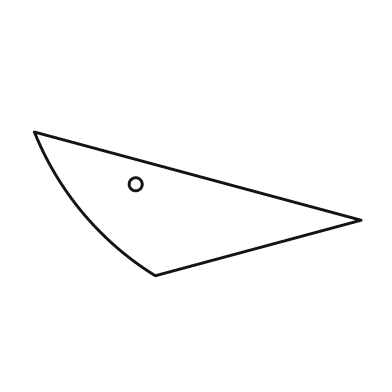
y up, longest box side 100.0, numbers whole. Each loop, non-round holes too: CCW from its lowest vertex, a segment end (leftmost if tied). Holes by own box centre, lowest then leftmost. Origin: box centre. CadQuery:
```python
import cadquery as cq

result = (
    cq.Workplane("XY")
    .moveTo(-13.0, -22.0)
    .lineTo(50.0, -5.0)
    .lineTo(-50.0, 22.0)
    .threePointArc((-35.0, -3.0), (-13.0, -22.0))
    .close()
    .moveTo(-19.0, 6.0)
    .circle(2.0)
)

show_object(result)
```